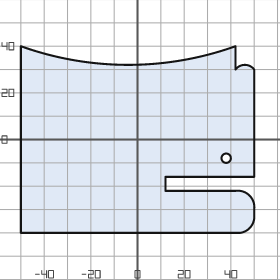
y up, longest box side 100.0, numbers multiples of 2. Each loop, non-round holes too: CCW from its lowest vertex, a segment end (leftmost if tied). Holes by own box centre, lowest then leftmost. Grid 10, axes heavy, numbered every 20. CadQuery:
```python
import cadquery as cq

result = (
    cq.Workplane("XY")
    .moveTo(-50.0, -40.0)
    .lineTo(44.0, -40.0)
    .threePointArc((48.0, -38.0), (50.0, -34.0))
    .lineTo(50.0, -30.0)
    .threePointArc((48.0, -24.0), (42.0, -22.0))
    .lineTo(12.0, -22.0)
    .lineTo(12.0, -16.0)
    .lineTo(50.0, -16.0)
    .lineTo(50.0, 30.0)
    .threePointArc((46.0, 32.0), (42.0, 30.0))
    .lineTo(42.0, 40.0)
    .threePointArc((-4.0, 32.0), (-50.0, 40.0))
    .close()
    .moveTo(38.0, -8.0)
    .circle(2.0)
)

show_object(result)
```